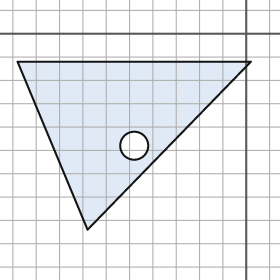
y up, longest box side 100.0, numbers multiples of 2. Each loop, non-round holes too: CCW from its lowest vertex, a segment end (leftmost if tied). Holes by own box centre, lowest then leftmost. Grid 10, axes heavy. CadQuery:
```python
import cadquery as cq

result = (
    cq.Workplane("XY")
    .moveTo(-68.0, -84.0)
    .lineTo(2.0, -12.0)
    .lineTo(-98.0, -12.0)
    .close()
    .moveTo(-48.0, -48.0)
    .circle(6.0)
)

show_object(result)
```